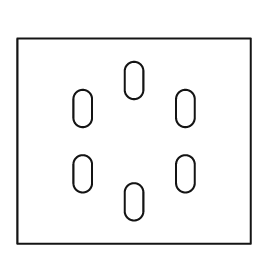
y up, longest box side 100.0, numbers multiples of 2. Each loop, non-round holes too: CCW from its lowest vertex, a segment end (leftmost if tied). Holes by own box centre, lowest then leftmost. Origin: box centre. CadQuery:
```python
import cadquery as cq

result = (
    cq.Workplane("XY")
    .moveTo(-50.0, -44.0)
    .lineTo(50.0, -44.0)
    .lineTo(50.0, 44.0)
    .lineTo(-50.0, 44.0)
    .close()
    .moveTo(-4.0, -30.0)
    .threePointArc((0.0, -34.0), (4.0, -30.0))
    .lineTo(4.0, -22.0)
    .threePointArc((0.0, -18.0), (-4.0, -22.0))
    .close()
    .moveTo(-26.0, -18.0)
    .threePointArc((-22.0, -22.0), (-18.0, -18.0))
    .lineTo(-18.0, -10.0)
    .threePointArc((-22.0, -6.0), (-26.0, -10.0))
    .close()
    .moveTo(18.0, -18.0)
    .threePointArc((22.0, -22.0), (26.0, -18.0))
    .lineTo(26.0, -10.0)
    .threePointArc((22.0, -6.0), (18.0, -10.0))
    .close()
    .moveTo(-26.0, 10.0)
    .threePointArc((-22.0, 6.0), (-18.0, 10.0))
    .lineTo(-18.0, 18.0)
    .threePointArc((-22.0, 22.0), (-26.0, 18.0))
    .close()
    .moveTo(18.0, 10.0)
    .threePointArc((22.0, 6.0), (26.0, 10.0))
    .lineTo(26.0, 18.0)
    .threePointArc((22.0, 22.0), (18.0, 18.0))
    .close()
    .moveTo(-4.0, 22.0)
    .threePointArc((0.0, 18.0), (4.0, 22.0))
    .lineTo(4.0, 30.0)
    .threePointArc((0.0, 34.0), (-4.0, 30.0))
    .close()
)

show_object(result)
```